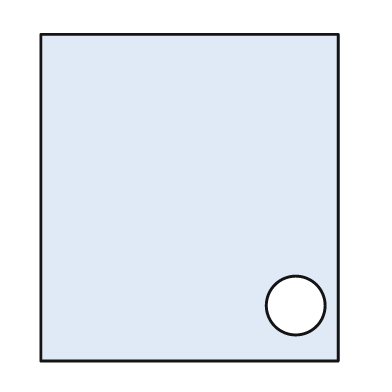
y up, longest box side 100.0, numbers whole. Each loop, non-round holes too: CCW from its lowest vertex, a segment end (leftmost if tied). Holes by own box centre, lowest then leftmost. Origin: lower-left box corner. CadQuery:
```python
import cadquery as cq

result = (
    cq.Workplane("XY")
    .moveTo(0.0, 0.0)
    .lineTo(91.0, 0.0)
    .lineTo(91.0, 100.0)
    .lineTo(0.0, 100.0)
    .close()
    .moveTo(78.0, 17.0)
    .circle(9.0)
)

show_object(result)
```